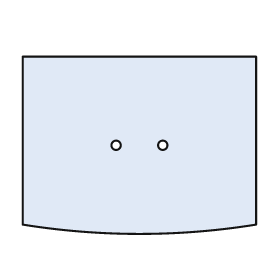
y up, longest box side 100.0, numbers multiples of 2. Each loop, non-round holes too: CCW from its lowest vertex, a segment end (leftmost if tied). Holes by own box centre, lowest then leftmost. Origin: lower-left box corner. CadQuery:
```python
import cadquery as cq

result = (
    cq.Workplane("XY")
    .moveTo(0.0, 4.0)
    .threePointArc((50.0, 0.0), (100.0, 4.0))
    .lineTo(100.0, 76.0)
    .lineTo(0.0, 76.0)
    .close()
    .moveTo(40.0, 38.0)
    .circle(2.0)
    .moveTo(60.0, 38.0)
    .circle(2.0)
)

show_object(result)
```